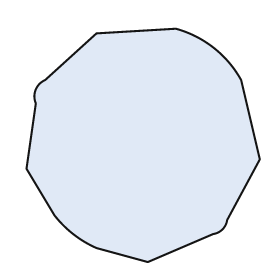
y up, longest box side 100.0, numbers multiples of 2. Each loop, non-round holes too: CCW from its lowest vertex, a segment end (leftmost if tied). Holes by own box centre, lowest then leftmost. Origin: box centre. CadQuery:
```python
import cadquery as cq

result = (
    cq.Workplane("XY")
    .moveTo(2.0, -50.0)
    .lineTo(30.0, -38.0)
    .threePointArc((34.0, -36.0), (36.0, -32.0))
    .lineTo(50.0, -6.0)
    .lineTo(42.0, 28.0)
    .threePointArc((30.0, 42.0), (14.0, 50.0))
    .lineTo(-20.0, 48.0)
    .lineTo(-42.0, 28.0)
    .threePointArc((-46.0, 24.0), (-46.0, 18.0))
    .lineTo(-50.0, -10.0)
    .lineTo(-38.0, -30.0)
    .threePointArc((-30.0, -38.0), (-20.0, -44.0))
    .close()
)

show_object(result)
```